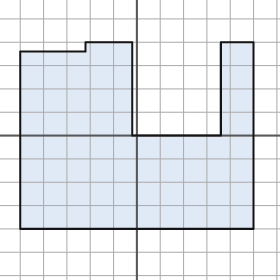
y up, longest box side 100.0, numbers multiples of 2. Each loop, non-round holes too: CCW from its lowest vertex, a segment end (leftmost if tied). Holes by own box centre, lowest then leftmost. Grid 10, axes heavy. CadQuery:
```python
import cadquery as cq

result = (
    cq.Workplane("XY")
    .moveTo(-50.0, -40.0)
    .lineTo(50.0, -40.0)
    .lineTo(50.0, 40.0)
    .lineTo(36.0, 40.0)
    .lineTo(36.0, 0.0)
    .lineTo(-2.0, 0.0)
    .lineTo(-2.0, 40.0)
    .lineTo(-22.0, 40.0)
    .lineTo(-22.0, 36.0)
    .lineTo(-50.0, 36.0)
    .close()
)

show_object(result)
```